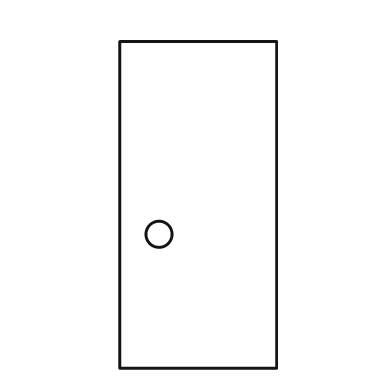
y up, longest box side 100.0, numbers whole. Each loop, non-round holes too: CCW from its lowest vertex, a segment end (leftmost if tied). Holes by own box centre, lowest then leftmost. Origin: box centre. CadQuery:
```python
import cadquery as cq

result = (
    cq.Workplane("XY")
    .moveTo(-24.0, -50.0)
    .lineTo(24.0, -50.0)
    .lineTo(24.0, 50.0)
    .lineTo(-24.0, 50.0)
    .close()
    .moveTo(-12.0, -9.0)
    .circle(4.0)
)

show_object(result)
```